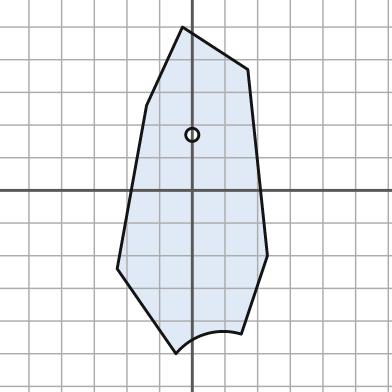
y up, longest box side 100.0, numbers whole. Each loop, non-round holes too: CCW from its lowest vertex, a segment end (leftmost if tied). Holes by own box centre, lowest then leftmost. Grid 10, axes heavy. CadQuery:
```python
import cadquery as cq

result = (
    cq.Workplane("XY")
    .moveTo(-5.0, -50.0)
    .threePointArc((4.0, -44.0), (15.0, -44.0))
    .lineTo(23.0, -20.0)
    .lineTo(17.0, 37.0)
    .lineTo(-3.0, 50.0)
    .lineTo(-14.0, 26.0)
    .lineTo(-23.0, -24.0)
    .close()
    .moveTo(0.0, 17.0)
    .circle(2.0)
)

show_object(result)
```